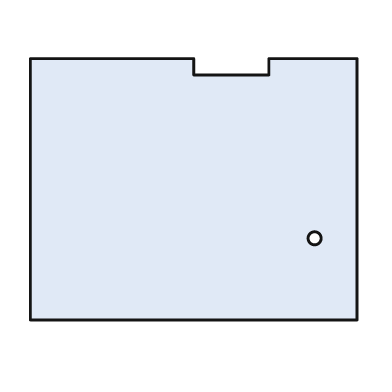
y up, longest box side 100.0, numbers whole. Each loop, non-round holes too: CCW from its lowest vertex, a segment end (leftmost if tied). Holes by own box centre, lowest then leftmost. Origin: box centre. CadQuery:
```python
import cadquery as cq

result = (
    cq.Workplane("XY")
    .moveTo(-50.0, -40.0)
    .lineTo(50.0, -40.0)
    .lineTo(50.0, 40.0)
    .lineTo(23.0, 40.0)
    .lineTo(23.0, 35.0)
    .lineTo(0.0, 35.0)
    .lineTo(0.0, 40.0)
    .lineTo(-50.0, 40.0)
    .close()
    .moveTo(37.0, -15.0)
    .circle(2.0)
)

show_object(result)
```